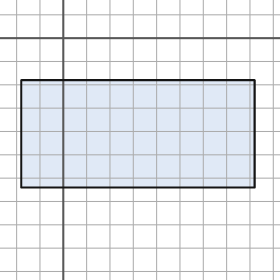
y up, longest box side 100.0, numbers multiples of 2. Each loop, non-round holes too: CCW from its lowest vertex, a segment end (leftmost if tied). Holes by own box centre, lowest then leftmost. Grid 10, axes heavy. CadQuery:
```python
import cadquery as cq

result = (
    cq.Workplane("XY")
    .moveTo(-18.0, -64.0)
    .lineTo(82.0, -64.0)
    .lineTo(82.0, -18.0)
    .lineTo(-18.0, -18.0)
    .close()
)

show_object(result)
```